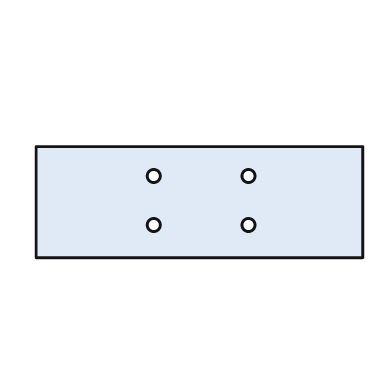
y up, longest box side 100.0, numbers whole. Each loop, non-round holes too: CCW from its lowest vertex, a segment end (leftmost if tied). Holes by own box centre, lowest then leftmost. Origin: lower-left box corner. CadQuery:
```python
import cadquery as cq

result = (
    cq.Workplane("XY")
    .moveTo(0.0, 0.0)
    .lineTo(100.0, 0.0)
    .lineTo(100.0, 34.0)
    .lineTo(0.0, 34.0)
    .close()
    .moveTo(36.0, 10.0)
    .circle(2.0)
    .moveTo(65.0, 10.0)
    .circle(2.0)
    .moveTo(36.0, 25.0)
    .circle(2.0)
    .moveTo(65.0, 25.0)
    .circle(2.0)
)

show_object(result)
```